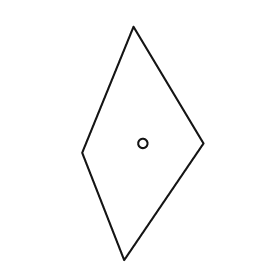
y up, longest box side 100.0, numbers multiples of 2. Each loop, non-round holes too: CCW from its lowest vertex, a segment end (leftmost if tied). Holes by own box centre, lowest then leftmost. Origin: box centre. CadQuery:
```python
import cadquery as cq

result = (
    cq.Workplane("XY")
    .moveTo(-8.0, -50.0)
    .lineTo(26.0, 0.0)
    .lineTo(-4.0, 50.0)
    .lineTo(-26.0, -4.0)
    .close()
    .moveTo(0.0, 0.0)
    .circle(2.0)
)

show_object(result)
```